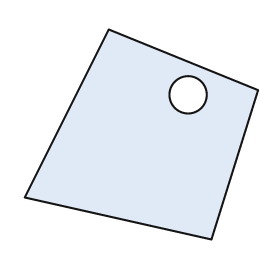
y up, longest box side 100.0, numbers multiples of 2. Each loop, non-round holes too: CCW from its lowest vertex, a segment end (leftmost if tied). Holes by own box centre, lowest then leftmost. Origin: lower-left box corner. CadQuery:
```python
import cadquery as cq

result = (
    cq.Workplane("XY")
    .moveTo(80.0, 0.0)
    .lineTo(100.0, 64.0)
    .lineTo(36.0, 90.0)
    .lineTo(0.0, 18.0)
    .close()
    .moveTo(70.0, 62.0)
    .circle(8.0)
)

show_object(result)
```